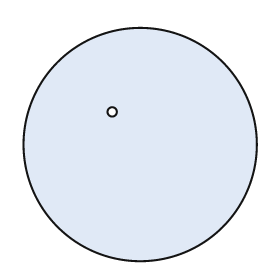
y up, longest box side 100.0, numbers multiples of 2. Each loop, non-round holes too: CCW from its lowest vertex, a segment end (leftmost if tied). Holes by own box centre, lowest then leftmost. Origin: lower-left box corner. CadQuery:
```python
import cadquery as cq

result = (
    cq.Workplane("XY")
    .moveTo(50.0, 50.0)
    .circle(50.0)
    .moveTo(38.0, 64.0)
    .circle(2.0)
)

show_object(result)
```